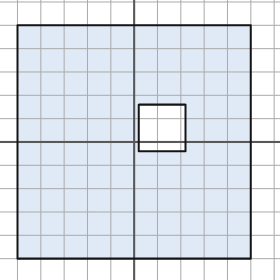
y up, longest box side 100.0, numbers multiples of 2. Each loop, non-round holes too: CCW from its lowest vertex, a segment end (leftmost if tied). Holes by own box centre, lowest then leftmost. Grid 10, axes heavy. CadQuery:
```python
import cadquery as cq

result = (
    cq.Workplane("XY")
    .moveTo(-50.0, -50.0)
    .lineTo(50.0, -50.0)
    .lineTo(50.0, 50.0)
    .lineTo(-50.0, 50.0)
    .close()
    .moveTo(2.0, -4.0)
    .lineTo(22.0, -4.0)
    .lineTo(22.0, 16.0)
    .lineTo(2.0, 16.0)
    .close()
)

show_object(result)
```